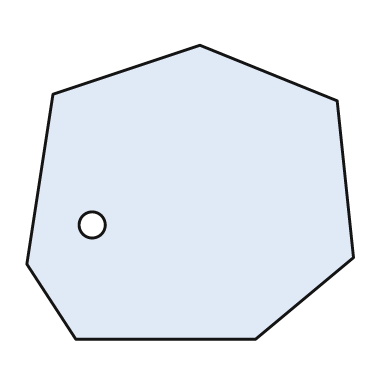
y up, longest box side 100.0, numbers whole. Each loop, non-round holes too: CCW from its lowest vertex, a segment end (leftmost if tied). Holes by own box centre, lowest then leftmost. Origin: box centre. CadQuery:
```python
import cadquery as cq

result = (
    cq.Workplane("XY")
    .moveTo(-35.0, -45.0)
    .lineTo(20.0, -45.0)
    .lineTo(50.0, -20.0)
    .lineTo(45.0, 28.0)
    .lineTo(3.0, 45.0)
    .lineTo(-42.0, 30.0)
    .lineTo(-50.0, -22.0)
    .close()
    .moveTo(-30.0, -10.0)
    .circle(4.0)
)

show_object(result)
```